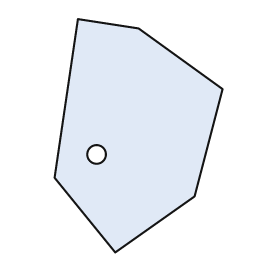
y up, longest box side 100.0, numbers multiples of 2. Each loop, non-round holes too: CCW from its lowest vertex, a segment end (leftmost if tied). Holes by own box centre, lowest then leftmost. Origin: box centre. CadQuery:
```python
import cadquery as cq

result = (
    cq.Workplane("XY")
    .moveTo(-10.0, -50.0)
    .lineTo(24.0, -26.0)
    .lineTo(36.0, 20.0)
    .lineTo(0.0, 46.0)
    .lineTo(-26.0, 50.0)
    .lineTo(-36.0, -18.0)
    .close()
    .moveTo(-18.0, -8.0)
    .circle(4.0)
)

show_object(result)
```